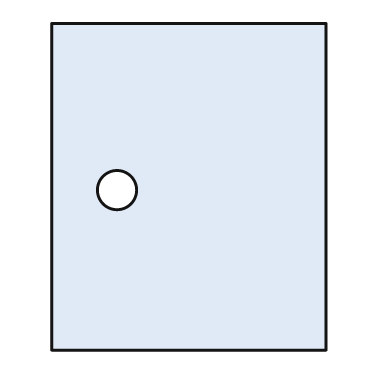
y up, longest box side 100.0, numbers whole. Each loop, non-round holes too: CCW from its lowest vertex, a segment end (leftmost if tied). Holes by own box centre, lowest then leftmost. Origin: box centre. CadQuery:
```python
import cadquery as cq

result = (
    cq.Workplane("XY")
    .moveTo(-42.0, -50.0)
    .lineTo(42.0, -50.0)
    .lineTo(42.0, 50.0)
    .lineTo(-42.0, 50.0)
    .close()
    .moveTo(-22.0, -1.0)
    .circle(6.0)
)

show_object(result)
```